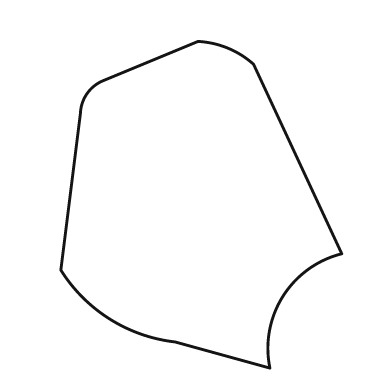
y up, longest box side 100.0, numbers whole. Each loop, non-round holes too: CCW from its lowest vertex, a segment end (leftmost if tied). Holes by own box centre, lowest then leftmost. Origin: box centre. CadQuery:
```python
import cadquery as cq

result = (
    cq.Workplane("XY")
    .moveTo(21.0, -50.0)
    .threePointArc((25.0, -28.0), (43.0, -15.0))
    .lineTo(16.0, 43.0)
    .threePointArc((8.0, 48.0), (-1.0, 50.0))
    .lineTo(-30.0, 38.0)
    .threePointArc((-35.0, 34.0), (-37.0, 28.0))
    .lineTo(-43.0, -20.0)
    .threePointArc((-28.0, -35.0), (-8.0, -42.0))
    .close()
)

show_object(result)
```